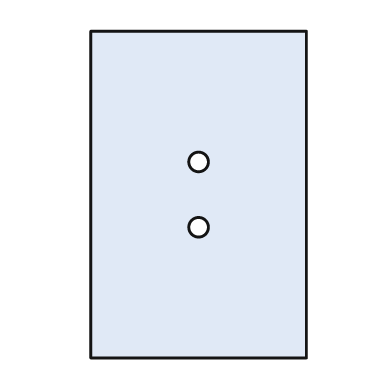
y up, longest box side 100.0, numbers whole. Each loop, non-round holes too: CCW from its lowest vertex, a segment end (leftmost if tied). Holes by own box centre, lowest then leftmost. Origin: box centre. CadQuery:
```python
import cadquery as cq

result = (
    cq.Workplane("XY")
    .moveTo(-33.0, -50.0)
    .lineTo(33.0, -50.0)
    .lineTo(33.0, 50.0)
    .lineTo(-33.0, 50.0)
    .close()
    .moveTo(0.0, -10.0)
    .circle(3.0)
    .moveTo(0.0, 10.0)
    .circle(3.0)
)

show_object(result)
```